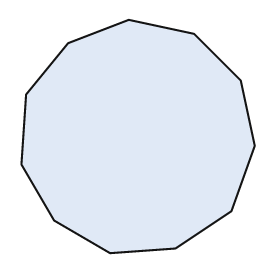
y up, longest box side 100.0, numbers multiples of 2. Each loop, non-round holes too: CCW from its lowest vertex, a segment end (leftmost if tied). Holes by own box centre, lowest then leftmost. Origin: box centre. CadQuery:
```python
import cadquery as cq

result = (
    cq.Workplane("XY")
    .moveTo(-12.0, -50.0)
    .lineTo(16.0, -48.0)
    .lineTo(40.0, -32.0)
    .lineTo(50.0, -4.0)
    .lineTo(44.0, 24.0)
    .lineTo(24.0, 44.0)
    .lineTo(-4.0, 50.0)
    .lineTo(-30.0, 40.0)
    .lineTo(-48.0, 18.0)
    .lineTo(-50.0, -12.0)
    .lineTo(-36.0, -36.0)
    .close()
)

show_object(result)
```